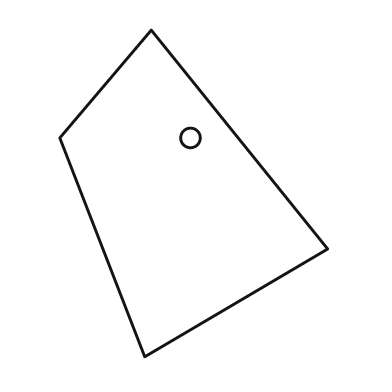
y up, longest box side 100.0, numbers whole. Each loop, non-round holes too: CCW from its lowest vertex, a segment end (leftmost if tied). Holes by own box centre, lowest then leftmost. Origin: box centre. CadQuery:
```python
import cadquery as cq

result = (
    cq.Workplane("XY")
    .moveTo(-15.0, -50.0)
    .lineTo(41.0, -17.0)
    .lineTo(-13.0, 50.0)
    .lineTo(-41.0, 17.0)
    .close()
    .moveTo(-1.0, 17.0)
    .circle(3.0)
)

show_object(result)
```